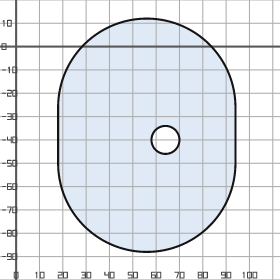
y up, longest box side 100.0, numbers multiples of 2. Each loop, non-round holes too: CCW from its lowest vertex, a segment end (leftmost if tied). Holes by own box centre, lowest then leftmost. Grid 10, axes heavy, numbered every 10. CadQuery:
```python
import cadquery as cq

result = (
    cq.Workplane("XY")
    .moveTo(18.0, -50.0)
    .threePointArc((56.0, -88.0), (94.0, -50.0))
    .lineTo(94.0, -26.0)
    .threePointArc((56.0, 12.0), (18.0, -26.0))
    .close()
    .moveTo(64.0, -40.0)
    .circle(6.0)
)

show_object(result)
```